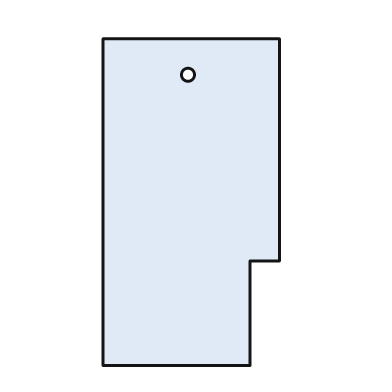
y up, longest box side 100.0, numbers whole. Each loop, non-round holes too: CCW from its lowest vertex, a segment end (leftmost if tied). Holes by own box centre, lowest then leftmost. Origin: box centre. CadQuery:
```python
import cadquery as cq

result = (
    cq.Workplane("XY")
    .moveTo(-27.0, -50.0)
    .lineTo(18.0, -50.0)
    .lineTo(18.0, -18.0)
    .lineTo(27.0, -18.0)
    .lineTo(27.0, 50.0)
    .lineTo(-27.0, 50.0)
    .close()
    .moveTo(-1.0, 39.0)
    .circle(2.0)
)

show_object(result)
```